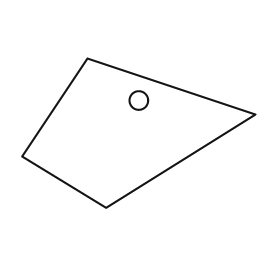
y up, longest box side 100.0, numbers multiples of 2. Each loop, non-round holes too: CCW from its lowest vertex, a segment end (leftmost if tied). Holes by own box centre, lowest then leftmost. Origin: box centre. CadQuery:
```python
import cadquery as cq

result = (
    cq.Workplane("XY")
    .moveTo(-14.0, -32.0)
    .lineTo(50.0, 8.0)
    .lineTo(-22.0, 32.0)
    .lineTo(-50.0, -10.0)
    .close()
    .moveTo(0.0, 14.0)
    .circle(4.0)
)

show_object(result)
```